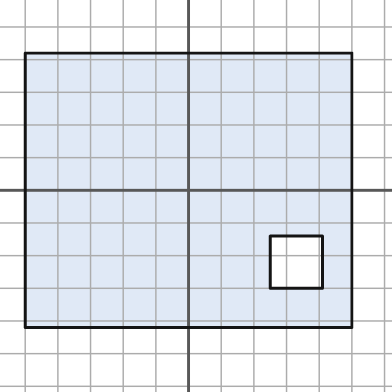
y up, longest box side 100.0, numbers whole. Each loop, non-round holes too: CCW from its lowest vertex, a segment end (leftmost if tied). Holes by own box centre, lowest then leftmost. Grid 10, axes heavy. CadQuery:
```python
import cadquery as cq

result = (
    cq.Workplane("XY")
    .moveTo(-50.0, -42.0)
    .lineTo(50.0, -42.0)
    .lineTo(50.0, 42.0)
    .lineTo(-50.0, 42.0)
    .close()
    .moveTo(25.0, -30.0)
    .lineTo(41.0, -30.0)
    .lineTo(41.0, -14.0)
    .lineTo(25.0, -14.0)
    .close()
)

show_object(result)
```